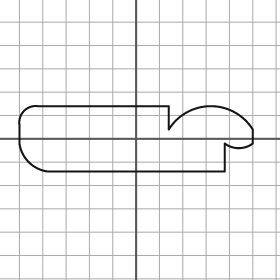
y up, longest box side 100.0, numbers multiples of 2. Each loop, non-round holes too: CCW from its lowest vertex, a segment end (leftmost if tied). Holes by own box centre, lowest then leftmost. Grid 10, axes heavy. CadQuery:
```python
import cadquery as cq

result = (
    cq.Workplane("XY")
    .moveTo(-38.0, -14.0)
    .lineTo(38.0, -14.0)
    .lineTo(38.0, -2.0)
    .threePointArc((44.0, -4.0), (50.0, -2.0))
    .lineTo(50.0, 4.0)
    .threePointArc((32.0, 14.0), (14.0, 4.0))
    .lineTo(14.0, 14.0)
    .lineTo(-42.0, 14.0)
    .threePointArc((-48.0, 12.0), (-50.0, 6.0))
    .lineTo(-50.0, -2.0)
    .threePointArc((-46.0, -10.0), (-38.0, -14.0))
    .close()
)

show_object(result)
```